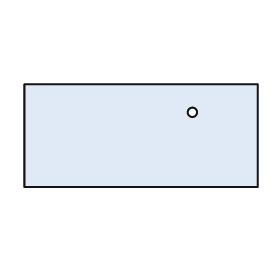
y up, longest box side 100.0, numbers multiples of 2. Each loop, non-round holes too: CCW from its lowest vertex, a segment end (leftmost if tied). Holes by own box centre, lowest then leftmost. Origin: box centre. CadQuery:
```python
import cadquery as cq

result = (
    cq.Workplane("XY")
    .moveTo(-50.0, -22.0)
    .lineTo(50.0, -22.0)
    .lineTo(50.0, 22.0)
    .lineTo(-50.0, 22.0)
    .close()
    .moveTo(22.0, 10.0)
    .circle(2.0)
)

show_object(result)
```